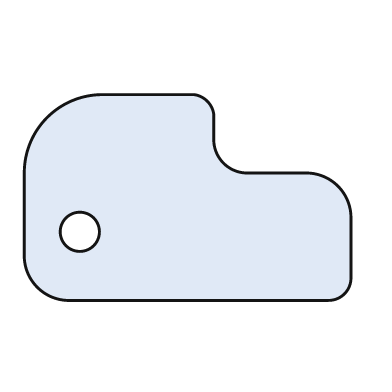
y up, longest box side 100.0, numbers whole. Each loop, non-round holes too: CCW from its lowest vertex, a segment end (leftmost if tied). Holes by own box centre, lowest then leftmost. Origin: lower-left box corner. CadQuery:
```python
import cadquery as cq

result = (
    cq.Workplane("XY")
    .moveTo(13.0, 0.0)
    .lineTo(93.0, 0.0)
    .threePointArc((98.0, 2.0), (100.0, 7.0))
    .lineTo(100.0, 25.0)
    .threePointArc((96.0, 35.0), (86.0, 39.0))
    .lineTo(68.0, 39.0)
    .threePointArc((61.0, 42.0), (58.0, 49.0))
    .lineTo(58.0, 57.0)
    .threePointArc((56.0, 61.0), (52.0, 63.0))
    .lineTo(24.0, 63.0)
    .threePointArc((7.0, 56.0), (0.0, 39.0))
    .lineTo(0.0, 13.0)
    .threePointArc((4.0, 4.0), (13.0, 0.0))
    .close()
    .moveTo(17.0, 21.0)
    .circle(6.0)
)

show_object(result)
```